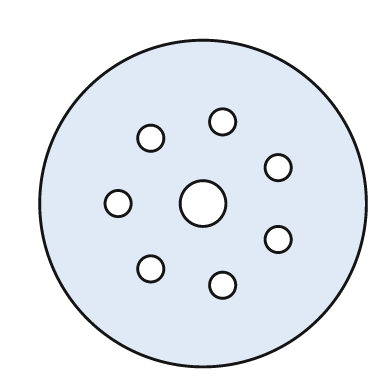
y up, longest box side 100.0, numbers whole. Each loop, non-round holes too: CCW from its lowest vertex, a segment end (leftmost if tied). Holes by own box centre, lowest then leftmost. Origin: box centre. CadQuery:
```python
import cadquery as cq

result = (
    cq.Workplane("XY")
    .moveTo(0.0, 0.0)
    .circle(50.0)
    .moveTo(6.0, -25.0)
    .circle(4.0)
    .moveTo(-16.0, -20.0)
    .circle(4.0)
    .moveTo(23.0, -11.0)
    .circle(4.0)
    .moveTo(-26.0, 0.0)
    .circle(4.0)
    .moveTo(0.0, 0.0)
    .circle(7.0)
    .moveTo(23.0, 11.0)
    .circle(4.0)
    .moveTo(-16.0, 20.0)
    .circle(4.0)
    .moveTo(6.0, 25.0)
    .circle(4.0)
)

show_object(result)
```